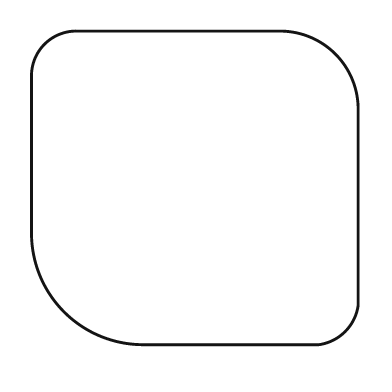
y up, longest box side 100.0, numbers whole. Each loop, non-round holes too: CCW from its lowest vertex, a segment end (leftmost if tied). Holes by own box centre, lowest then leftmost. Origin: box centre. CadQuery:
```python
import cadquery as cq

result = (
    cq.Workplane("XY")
    .moveTo(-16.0, -48.0)
    .lineTo(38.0, -48.0)
    .threePointArc((46.0, -44.0), (50.0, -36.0))
    .lineTo(50.0, 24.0)
    .threePointArc((43.0, 41.0), (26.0, 48.0))
    .lineTo(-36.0, 48.0)
    .threePointArc((-46.0, 44.0), (-50.0, 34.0))
    .lineTo(-50.0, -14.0)
    .threePointArc((-40.0, -38.0), (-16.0, -48.0))
    .close()
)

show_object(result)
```